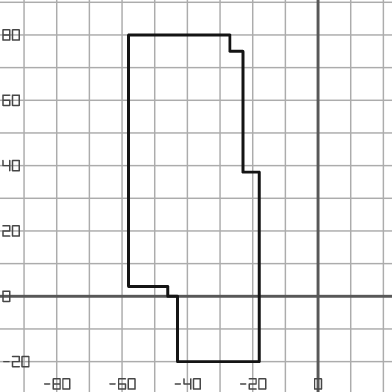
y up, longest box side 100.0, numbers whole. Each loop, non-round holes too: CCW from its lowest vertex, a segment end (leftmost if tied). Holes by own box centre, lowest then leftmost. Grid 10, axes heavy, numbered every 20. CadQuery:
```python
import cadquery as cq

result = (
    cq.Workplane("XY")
    .moveTo(-43.0, -20.0)
    .lineTo(-18.0, -20.0)
    .lineTo(-18.0, 38.0)
    .lineTo(-23.0, 38.0)
    .lineTo(-23.0, 75.0)
    .lineTo(-27.0, 75.0)
    .lineTo(-27.0, 80.0)
    .lineTo(-58.0, 80.0)
    .lineTo(-58.0, 3.0)
    .lineTo(-46.0, 3.0)
    .lineTo(-46.0, 0.0)
    .lineTo(-43.0, 0.0)
    .close()
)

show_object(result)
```